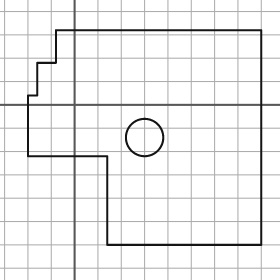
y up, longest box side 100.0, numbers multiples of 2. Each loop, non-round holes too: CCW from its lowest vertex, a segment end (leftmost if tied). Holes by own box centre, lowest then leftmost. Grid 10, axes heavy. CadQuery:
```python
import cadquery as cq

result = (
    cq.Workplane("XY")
    .moveTo(14.0, -60.0)
    .lineTo(80.0, -60.0)
    .lineTo(80.0, 32.0)
    .lineTo(-8.0, 32.0)
    .lineTo(-8.0, 18.0)
    .lineTo(-16.0, 18.0)
    .lineTo(-16.0, 4.0)
    .lineTo(-20.0, 4.0)
    .lineTo(-20.0, -22.0)
    .lineTo(14.0, -22.0)
    .close()
    .moveTo(30.0, -14.0)
    .circle(8.0)
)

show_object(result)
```